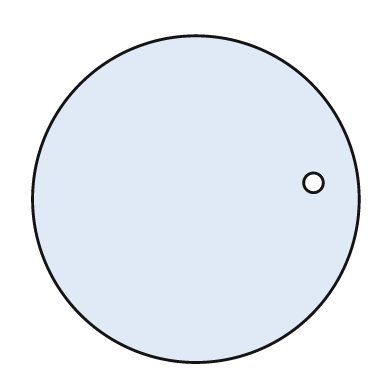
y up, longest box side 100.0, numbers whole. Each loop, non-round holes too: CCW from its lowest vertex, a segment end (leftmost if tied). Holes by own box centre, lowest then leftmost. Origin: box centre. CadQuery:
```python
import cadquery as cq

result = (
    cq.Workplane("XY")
    .moveTo(0.0, 0.0)
    .circle(50.0)
    .moveTo(36.0, 5.0)
    .circle(3.0)
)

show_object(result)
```